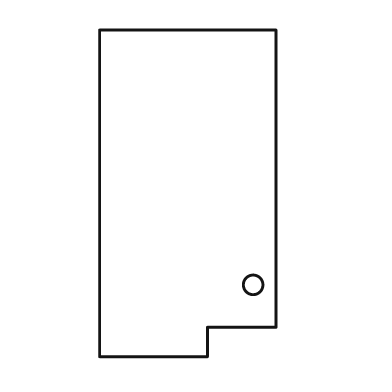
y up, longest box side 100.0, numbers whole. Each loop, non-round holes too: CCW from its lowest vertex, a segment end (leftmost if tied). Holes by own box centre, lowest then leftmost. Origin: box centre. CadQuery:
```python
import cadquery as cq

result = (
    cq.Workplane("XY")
    .moveTo(-27.0, -50.0)
    .lineTo(6.0, -50.0)
    .lineTo(6.0, -41.0)
    .lineTo(27.0, -41.0)
    .lineTo(27.0, 50.0)
    .lineTo(-27.0, 50.0)
    .close()
    .moveTo(20.0, -28.0)
    .circle(3.0)
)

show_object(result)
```